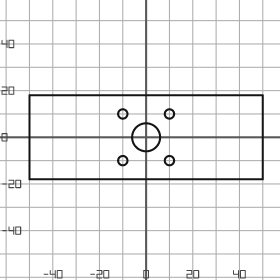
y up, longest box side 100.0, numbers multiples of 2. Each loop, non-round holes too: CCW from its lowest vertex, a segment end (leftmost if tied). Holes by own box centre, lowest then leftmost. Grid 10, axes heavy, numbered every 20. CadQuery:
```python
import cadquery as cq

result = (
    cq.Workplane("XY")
    .moveTo(-50.0, -18.0)
    .lineTo(50.0, -18.0)
    .lineTo(50.0, 18.0)
    .lineTo(-50.0, 18.0)
    .close()
    .moveTo(-10.0, -10.0)
    .circle(2.0)
    .moveTo(10.0, -10.0)
    .circle(2.0)
    .moveTo(0.0, 0.0)
    .circle(6.0)
    .moveTo(-10.0, 10.0)
    .circle(2.0)
    .moveTo(10.0, 10.0)
    .circle(2.0)
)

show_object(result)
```